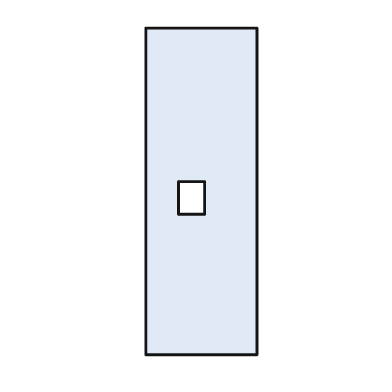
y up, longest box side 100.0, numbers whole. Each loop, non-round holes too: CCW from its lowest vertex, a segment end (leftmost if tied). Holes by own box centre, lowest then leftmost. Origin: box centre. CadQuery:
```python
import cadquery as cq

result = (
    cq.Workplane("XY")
    .moveTo(-17.0, -50.0)
    .lineTo(17.0, -50.0)
    .lineTo(17.0, 50.0)
    .lineTo(-17.0, 50.0)
    .close()
    .moveTo(-7.0, -7.0)
    .lineTo(1.0, -7.0)
    .lineTo(1.0, 3.0)
    .lineTo(-7.0, 3.0)
    .close()
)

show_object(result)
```